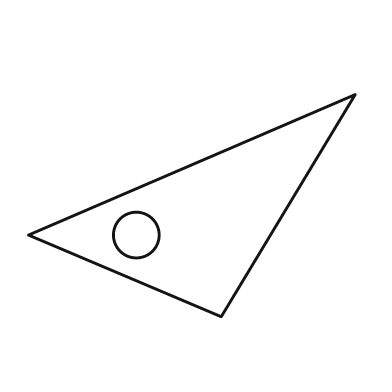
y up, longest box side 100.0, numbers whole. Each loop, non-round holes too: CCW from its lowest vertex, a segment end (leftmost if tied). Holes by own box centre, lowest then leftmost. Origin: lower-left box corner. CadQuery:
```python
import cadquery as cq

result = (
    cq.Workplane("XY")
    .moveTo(59.0, 0.0)
    .lineTo(100.0, 68.0)
    .lineTo(0.0, 25.0)
    .close()
    .moveTo(33.0, 25.0)
    .circle(7.0)
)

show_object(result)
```